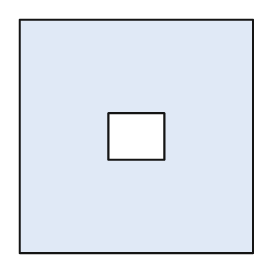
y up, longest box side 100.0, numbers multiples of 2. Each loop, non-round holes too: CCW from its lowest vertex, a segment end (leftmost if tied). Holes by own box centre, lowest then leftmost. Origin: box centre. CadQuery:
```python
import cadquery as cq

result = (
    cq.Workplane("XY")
    .moveTo(-50.0, -50.0)
    .lineTo(50.0, -50.0)
    .lineTo(50.0, 50.0)
    .lineTo(-50.0, 50.0)
    .close()
    .moveTo(-12.0, -10.0)
    .lineTo(12.0, -10.0)
    .lineTo(12.0, 10.0)
    .lineTo(-12.0, 10.0)
    .close()
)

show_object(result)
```